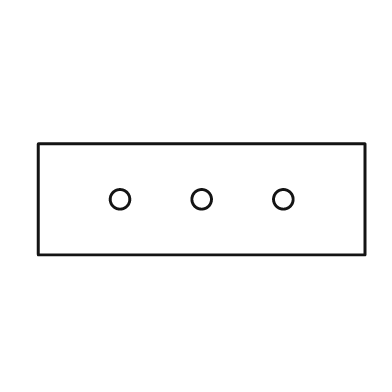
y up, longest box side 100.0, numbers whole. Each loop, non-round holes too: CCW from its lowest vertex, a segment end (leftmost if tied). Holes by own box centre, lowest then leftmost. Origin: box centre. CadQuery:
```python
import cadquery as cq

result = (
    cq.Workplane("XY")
    .moveTo(-50.0, -17.0)
    .lineTo(50.0, -17.0)
    .lineTo(50.0, 17.0)
    .lineTo(-50.0, 17.0)
    .close()
    .moveTo(-25.0, 0.0)
    .circle(3.0)
    .moveTo(0.0, 0.0)
    .circle(3.0)
    .moveTo(25.0, 0.0)
    .circle(3.0)
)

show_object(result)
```